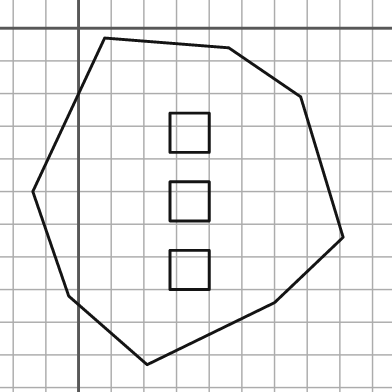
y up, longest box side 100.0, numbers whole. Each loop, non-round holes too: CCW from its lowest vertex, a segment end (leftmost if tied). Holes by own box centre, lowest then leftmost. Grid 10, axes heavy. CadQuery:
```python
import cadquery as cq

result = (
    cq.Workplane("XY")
    .moveTo(21.0, -103.0)
    .lineTo(60.0, -84.0)
    .lineTo(81.0, -64.0)
    .lineTo(68.0, -21.0)
    .lineTo(46.0, -6.0)
    .lineTo(8.0, -3.0)
    .lineTo(-14.0, -50.0)
    .lineTo(-3.0, -82.0)
    .close()
    .moveTo(28.0, -80.0)
    .lineTo(40.0, -80.0)
    .lineTo(40.0, -68.0)
    .lineTo(28.0, -68.0)
    .close()
    .moveTo(28.0, -59.0)
    .lineTo(40.0, -59.0)
    .lineTo(40.0, -47.0)
    .lineTo(28.0, -47.0)
    .close()
    .moveTo(28.0, -38.0)
    .lineTo(40.0, -38.0)
    .lineTo(40.0, -26.0)
    .lineTo(28.0, -26.0)
    .close()
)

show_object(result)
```